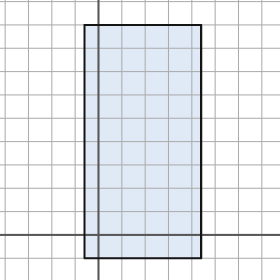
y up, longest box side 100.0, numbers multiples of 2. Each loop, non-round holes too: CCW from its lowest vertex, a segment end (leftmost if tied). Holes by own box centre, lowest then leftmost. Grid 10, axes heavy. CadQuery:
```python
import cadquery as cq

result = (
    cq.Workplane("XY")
    .moveTo(-6.0, -10.0)
    .lineTo(44.0, -10.0)
    .lineTo(44.0, 90.0)
    .lineTo(-6.0, 90.0)
    .close()
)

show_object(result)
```